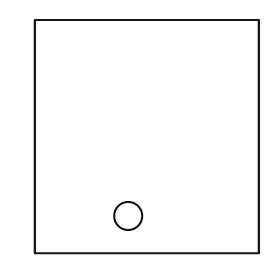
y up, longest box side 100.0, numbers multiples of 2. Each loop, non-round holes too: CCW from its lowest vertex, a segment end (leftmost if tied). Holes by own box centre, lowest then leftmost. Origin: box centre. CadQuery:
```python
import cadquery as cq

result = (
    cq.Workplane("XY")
    .moveTo(-48.0, -50.0)
    .lineTo(48.0, -50.0)
    .lineTo(48.0, 50.0)
    .lineTo(-48.0, 50.0)
    .close()
    .moveTo(-8.0, -34.0)
    .circle(6.0)
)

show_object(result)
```